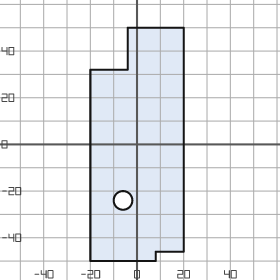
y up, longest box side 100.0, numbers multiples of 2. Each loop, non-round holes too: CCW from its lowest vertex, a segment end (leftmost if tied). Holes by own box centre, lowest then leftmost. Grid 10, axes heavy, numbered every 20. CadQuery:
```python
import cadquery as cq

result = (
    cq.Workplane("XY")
    .moveTo(-20.0, -50.0)
    .lineTo(8.0, -50.0)
    .lineTo(8.0, -46.0)
    .lineTo(20.0, -46.0)
    .lineTo(20.0, 50.0)
    .lineTo(-4.0, 50.0)
    .lineTo(-4.0, 32.0)
    .lineTo(-20.0, 32.0)
    .close()
    .moveTo(-6.0, -24.0)
    .circle(4.0)
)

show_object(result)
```